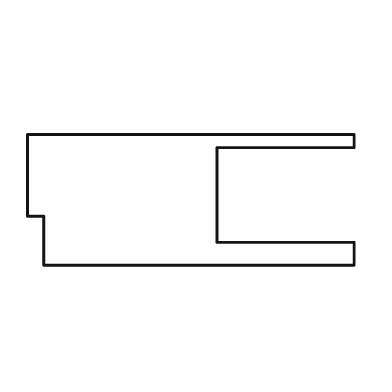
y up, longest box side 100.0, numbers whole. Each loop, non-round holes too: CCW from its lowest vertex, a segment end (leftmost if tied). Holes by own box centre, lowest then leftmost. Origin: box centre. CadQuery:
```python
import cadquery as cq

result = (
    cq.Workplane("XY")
    .moveTo(-45.0, -20.0)
    .lineTo(50.0, -20.0)
    .lineTo(50.0, -13.0)
    .lineTo(8.0, -13.0)
    .lineTo(8.0, 16.0)
    .lineTo(50.0, 16.0)
    .lineTo(50.0, 20.0)
    .lineTo(-50.0, 20.0)
    .lineTo(-50.0, -5.0)
    .lineTo(-45.0, -5.0)
    .close()
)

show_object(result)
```